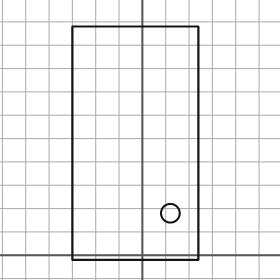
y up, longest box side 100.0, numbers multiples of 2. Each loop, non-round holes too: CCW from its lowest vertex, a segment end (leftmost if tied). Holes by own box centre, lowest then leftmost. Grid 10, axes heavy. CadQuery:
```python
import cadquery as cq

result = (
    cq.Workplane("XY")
    .moveTo(-30.0, -2.0)
    .lineTo(24.0, -2.0)
    .lineTo(24.0, 98.0)
    .lineTo(-30.0, 98.0)
    .close()
    .moveTo(12.0, 18.0)
    .circle(4.0)
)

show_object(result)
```